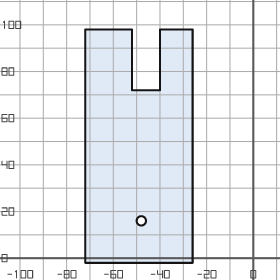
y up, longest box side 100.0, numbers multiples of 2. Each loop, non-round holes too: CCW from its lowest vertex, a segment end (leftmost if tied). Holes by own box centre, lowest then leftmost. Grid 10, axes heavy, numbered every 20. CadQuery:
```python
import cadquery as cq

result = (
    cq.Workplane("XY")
    .moveTo(-72.0, -2.0)
    .lineTo(-26.0, -2.0)
    .lineTo(-26.0, 98.0)
    .lineTo(-40.0, 98.0)
    .lineTo(-40.0, 72.0)
    .lineTo(-52.0, 72.0)
    .lineTo(-52.0, 98.0)
    .lineTo(-72.0, 98.0)
    .close()
    .moveTo(-48.0, 16.0)
    .circle(2.0)
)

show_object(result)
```